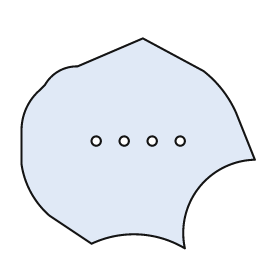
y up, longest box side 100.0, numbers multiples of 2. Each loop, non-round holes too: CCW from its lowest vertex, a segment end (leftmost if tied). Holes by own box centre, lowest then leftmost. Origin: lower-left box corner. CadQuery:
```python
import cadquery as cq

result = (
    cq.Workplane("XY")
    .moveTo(70.0, 0.0)
    .threePointArc((76.0, 26.0), (100.0, 38.0))
    .lineTo(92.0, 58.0)
    .threePointArc((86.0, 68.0), (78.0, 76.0))
    .lineTo(52.0, 90.0)
    .lineTo(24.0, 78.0)
    .threePointArc((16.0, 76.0), (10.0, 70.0))
    .lineTo(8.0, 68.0)
    .threePointArc((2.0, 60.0), (0.0, 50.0))
    .lineTo(0.0, 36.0)
    .threePointArc((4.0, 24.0), (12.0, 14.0))
    .lineTo(30.0, 2.0)
    .threePointArc((50.0, 6.0), (70.0, 0.0))
    .close()
    .moveTo(32.0, 46.0)
    .circle(2.0)
    .moveTo(44.0, 46.0)
    .circle(2.0)
    .moveTo(56.0, 46.0)
    .circle(2.0)
    .moveTo(68.0, 46.0)
    .circle(2.0)
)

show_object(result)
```